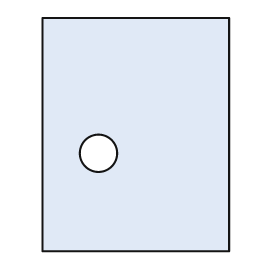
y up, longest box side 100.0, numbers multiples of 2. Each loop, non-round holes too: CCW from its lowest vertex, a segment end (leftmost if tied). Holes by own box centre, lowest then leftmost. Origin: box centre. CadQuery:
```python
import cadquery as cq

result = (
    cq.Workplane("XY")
    .moveTo(-40.0, -50.0)
    .lineTo(40.0, -50.0)
    .lineTo(40.0, 50.0)
    .lineTo(-40.0, 50.0)
    .close()
    .moveTo(-16.0, -8.0)
    .circle(8.0)
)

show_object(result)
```